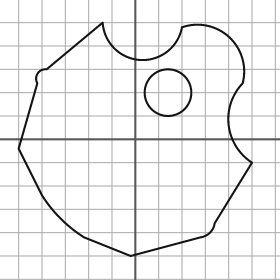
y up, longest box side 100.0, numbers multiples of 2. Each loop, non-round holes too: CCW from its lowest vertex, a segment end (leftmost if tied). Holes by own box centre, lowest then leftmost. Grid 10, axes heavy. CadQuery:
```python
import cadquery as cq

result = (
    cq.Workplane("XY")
    .moveTo(-2.0, -50.0)
    .lineTo(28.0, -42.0)
    .threePointArc((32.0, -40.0), (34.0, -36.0))
    .lineTo(50.0, -10.0)
    .threePointArc((40.0, 6.0), (46.0, 24.0))
    .threePointArc((40.0, 44.0), (20.0, 48.0))
    .threePointArc((2.0, 34.0), (-14.0, 50.0))
    .lineTo(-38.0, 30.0)
    .threePointArc((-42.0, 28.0), (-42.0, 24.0))
    .lineTo(-50.0, -4.0)
    .lineTo(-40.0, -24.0)
    .threePointArc((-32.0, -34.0), (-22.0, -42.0))
    .close()
    .moveTo(14.0, 20.0)
    .circle(10.0)
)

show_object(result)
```